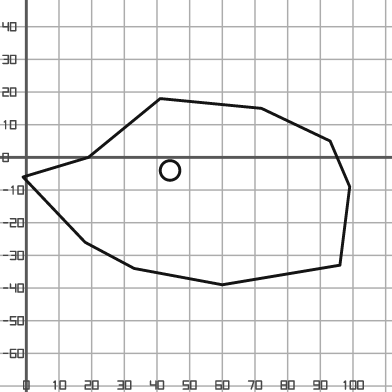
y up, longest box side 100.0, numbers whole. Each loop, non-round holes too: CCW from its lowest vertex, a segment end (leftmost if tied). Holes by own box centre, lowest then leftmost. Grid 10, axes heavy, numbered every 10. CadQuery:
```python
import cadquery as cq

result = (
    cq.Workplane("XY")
    .moveTo(60.0, -39.0)
    .lineTo(96.0, -33.0)
    .lineTo(99.0, -9.0)
    .lineTo(93.0, 5.0)
    .lineTo(72.0, 15.0)
    .lineTo(41.0, 18.0)
    .lineTo(19.0, 0.0)
    .lineTo(-1.0, -6.0)
    .lineTo(18.0, -26.0)
    .lineTo(33.0, -34.0)
    .close()
    .moveTo(44.0, -4.0)
    .circle(3.0)
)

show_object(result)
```